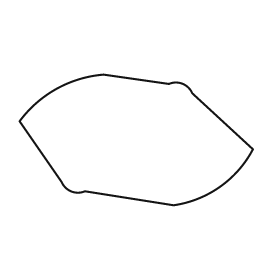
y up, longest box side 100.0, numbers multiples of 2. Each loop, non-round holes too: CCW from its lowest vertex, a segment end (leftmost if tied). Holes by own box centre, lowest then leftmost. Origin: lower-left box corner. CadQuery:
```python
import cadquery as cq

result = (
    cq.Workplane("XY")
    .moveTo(66.0, 0.0)
    .threePointArc((86.0, 8.0), (100.0, 24.0))
    .lineTo(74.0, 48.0)
    .threePointArc((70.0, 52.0), (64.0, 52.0))
    .lineTo(36.0, 56.0)
    .threePointArc((16.0, 50.0), (0.0, 36.0))
    .lineTo(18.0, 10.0)
    .threePointArc((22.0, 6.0), (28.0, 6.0))
    .close()
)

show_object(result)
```